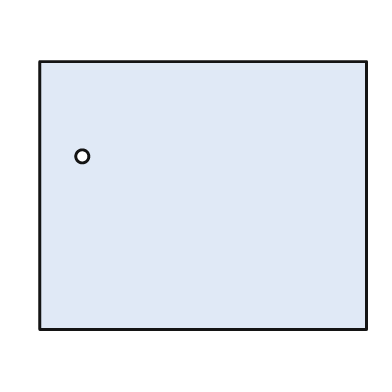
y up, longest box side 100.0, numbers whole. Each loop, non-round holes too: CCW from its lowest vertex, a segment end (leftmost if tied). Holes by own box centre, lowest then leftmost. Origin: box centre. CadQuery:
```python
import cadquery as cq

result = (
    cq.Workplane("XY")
    .moveTo(-50.0, -41.0)
    .lineTo(50.0, -41.0)
    .lineTo(50.0, 41.0)
    .lineTo(-50.0, 41.0)
    .close()
    .moveTo(-37.0, 12.0)
    .circle(2.0)
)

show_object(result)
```